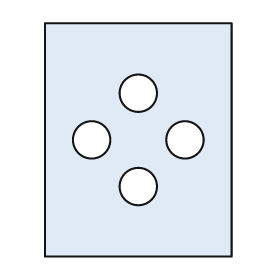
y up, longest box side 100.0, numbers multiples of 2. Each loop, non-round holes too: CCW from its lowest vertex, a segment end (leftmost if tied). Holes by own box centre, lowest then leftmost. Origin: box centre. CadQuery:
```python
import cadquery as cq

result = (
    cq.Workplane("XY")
    .moveTo(-40.0, -50.0)
    .lineTo(40.0, -50.0)
    .lineTo(40.0, 50.0)
    .lineTo(-40.0, 50.0)
    .close()
    .moveTo(0.0, -20.0)
    .circle(8.0)
    .moveTo(-20.0, 0.0)
    .circle(8.0)
    .moveTo(20.0, 0.0)
    .circle(8.0)
    .moveTo(0.0, 20.0)
    .circle(8.0)
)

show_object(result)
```